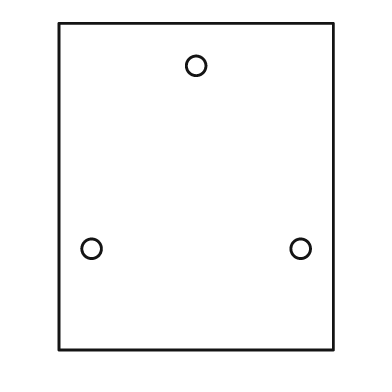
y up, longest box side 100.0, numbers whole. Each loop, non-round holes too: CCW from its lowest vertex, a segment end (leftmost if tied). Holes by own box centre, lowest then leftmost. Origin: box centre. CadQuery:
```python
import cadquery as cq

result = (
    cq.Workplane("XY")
    .moveTo(-42.0, -50.0)
    .lineTo(42.0, -50.0)
    .lineTo(42.0, 50.0)
    .lineTo(-42.0, 50.0)
    .close()
    .moveTo(-32.0, -19.0)
    .circle(3.0)
    .moveTo(32.0, -19.0)
    .circle(3.0)
    .moveTo(0.0, 37.0)
    .circle(3.0)
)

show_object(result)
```